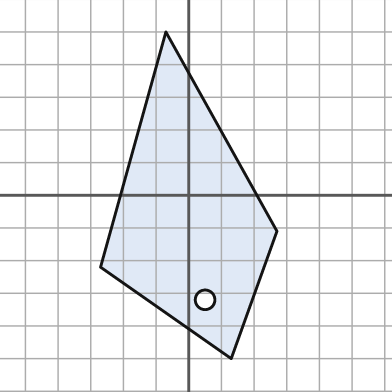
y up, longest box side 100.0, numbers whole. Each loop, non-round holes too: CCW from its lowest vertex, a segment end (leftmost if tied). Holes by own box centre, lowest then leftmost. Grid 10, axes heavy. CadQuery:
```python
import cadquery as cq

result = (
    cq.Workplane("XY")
    .moveTo(13.0, -50.0)
    .lineTo(27.0, -11.0)
    .lineTo(-7.0, 50.0)
    .lineTo(-27.0, -22.0)
    .close()
    .moveTo(5.0, -32.0)
    .circle(3.0)
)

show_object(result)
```